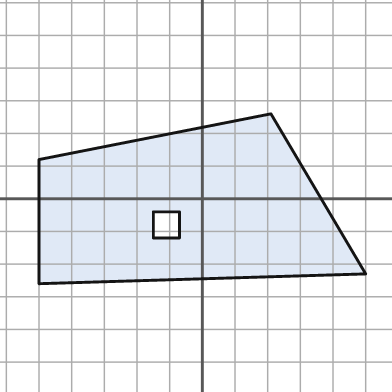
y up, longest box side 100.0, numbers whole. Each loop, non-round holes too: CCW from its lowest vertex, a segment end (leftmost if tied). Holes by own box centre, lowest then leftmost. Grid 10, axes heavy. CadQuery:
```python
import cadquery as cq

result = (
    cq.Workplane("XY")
    .moveTo(-50.0, -26.0)
    .lineTo(50.0, -23.0)
    .lineTo(21.0, 26.0)
    .lineTo(-50.0, 12.0)
    .close()
    .moveTo(-15.0, -12.0)
    .lineTo(-7.0, -12.0)
    .lineTo(-7.0, -4.0)
    .lineTo(-15.0, -4.0)
    .close()
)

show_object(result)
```